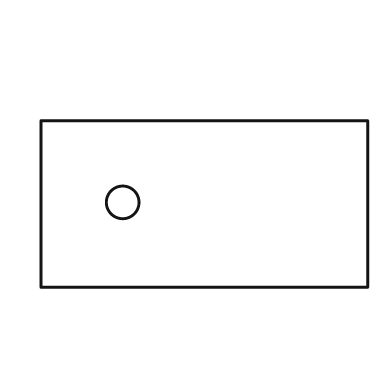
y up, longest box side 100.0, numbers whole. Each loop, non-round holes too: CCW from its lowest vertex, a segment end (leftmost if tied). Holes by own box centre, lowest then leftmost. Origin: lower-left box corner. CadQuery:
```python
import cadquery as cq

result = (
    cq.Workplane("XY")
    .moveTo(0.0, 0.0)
    .lineTo(100.0, 0.0)
    .lineTo(100.0, 51.0)
    .lineTo(0.0, 51.0)
    .close()
    .moveTo(25.0, 26.0)
    .circle(5.0)
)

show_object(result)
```